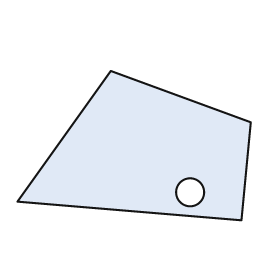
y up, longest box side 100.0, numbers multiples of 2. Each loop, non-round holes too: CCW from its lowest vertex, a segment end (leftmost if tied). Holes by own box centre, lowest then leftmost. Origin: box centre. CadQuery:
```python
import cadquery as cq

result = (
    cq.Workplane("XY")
    .moveTo(46.0, -32.0)
    .lineTo(50.0, 10.0)
    .lineTo(-10.0, 32.0)
    .lineTo(-50.0, -24.0)
    .close()
    .moveTo(24.0, -20.0)
    .circle(6.0)
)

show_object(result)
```